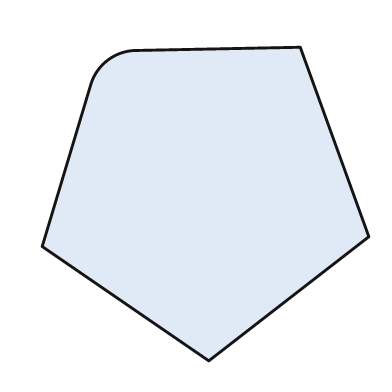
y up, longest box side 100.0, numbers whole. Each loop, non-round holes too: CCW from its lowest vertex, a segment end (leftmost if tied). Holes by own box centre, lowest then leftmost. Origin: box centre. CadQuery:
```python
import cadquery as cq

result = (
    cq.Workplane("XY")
    .moveTo(1.0, -48.0)
    .lineTo(50.0, -10.0)
    .lineTo(29.0, 48.0)
    .lineTo(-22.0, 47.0)
    .threePointArc((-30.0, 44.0), (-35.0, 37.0))
    .lineTo(-50.0, -13.0)
    .close()
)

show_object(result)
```